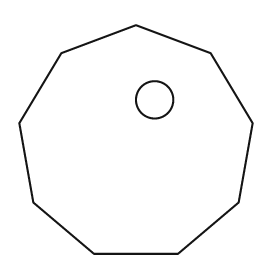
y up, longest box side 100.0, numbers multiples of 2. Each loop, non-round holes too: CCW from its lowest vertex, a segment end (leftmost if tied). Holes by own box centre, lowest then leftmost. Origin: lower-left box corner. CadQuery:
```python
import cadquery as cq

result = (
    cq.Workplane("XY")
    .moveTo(32.0, 0.0)
    .lineTo(68.0, 0.0)
    .lineTo(94.0, 22.0)
    .lineTo(100.0, 56.0)
    .lineTo(82.0, 86.0)
    .lineTo(50.0, 98.0)
    .lineTo(18.0, 86.0)
    .lineTo(0.0, 56.0)
    .lineTo(6.0, 22.0)
    .close()
    .moveTo(58.0, 66.0)
    .circle(8.0)
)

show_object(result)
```